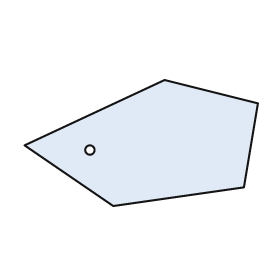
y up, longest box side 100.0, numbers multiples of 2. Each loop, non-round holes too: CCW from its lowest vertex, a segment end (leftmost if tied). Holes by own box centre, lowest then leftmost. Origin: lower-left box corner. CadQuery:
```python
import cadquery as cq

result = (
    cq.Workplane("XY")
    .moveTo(38.0, 0.0)
    .lineTo(94.0, 8.0)
    .lineTo(100.0, 44.0)
    .lineTo(60.0, 54.0)
    .lineTo(0.0, 26.0)
    .close()
    .moveTo(28.0, 24.0)
    .circle(2.0)
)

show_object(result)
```